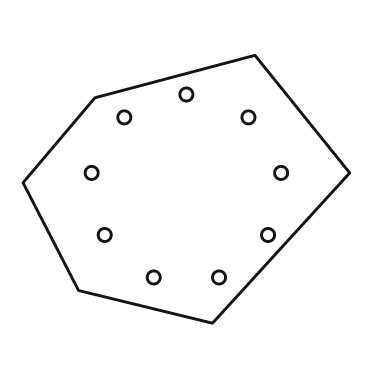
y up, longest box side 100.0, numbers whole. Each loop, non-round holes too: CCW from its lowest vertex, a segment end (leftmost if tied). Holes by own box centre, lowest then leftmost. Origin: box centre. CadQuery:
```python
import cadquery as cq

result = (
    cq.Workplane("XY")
    .moveTo(8.0, -41.0)
    .lineTo(50.0, 5.0)
    .lineTo(21.0, 41.0)
    .lineTo(-28.0, 28.0)
    .lineTo(-50.0, 2.0)
    .lineTo(-33.0, -31.0)
    .close()
    .moveTo(-10.0, -27.0)
    .circle(2.0)
    .moveTo(10.0, -27.0)
    .circle(2.0)
    .moveTo(-25.0, -14.0)
    .circle(2.0)
    .moveTo(25.0, -14.0)
    .circle(2.0)
    .moveTo(-29.0, 5.0)
    .circle(2.0)
    .moveTo(29.0, 5.0)
    .circle(2.0)
    .moveTo(-19.0, 22.0)
    .circle(2.0)
    .moveTo(19.0, 22.0)
    .circle(2.0)
    .moveTo(0.0, 29.0)
    .circle(2.0)
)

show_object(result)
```